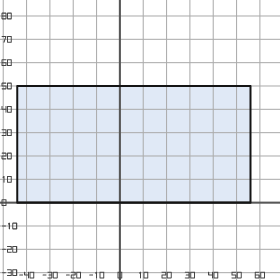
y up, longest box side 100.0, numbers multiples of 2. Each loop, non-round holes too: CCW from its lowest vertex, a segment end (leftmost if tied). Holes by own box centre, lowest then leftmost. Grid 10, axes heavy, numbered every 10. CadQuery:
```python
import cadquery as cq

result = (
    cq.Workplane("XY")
    .moveTo(-44.0, 0.0)
    .lineTo(56.0, 0.0)
    .lineTo(56.0, 50.0)
    .lineTo(-44.0, 50.0)
    .close()
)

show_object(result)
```